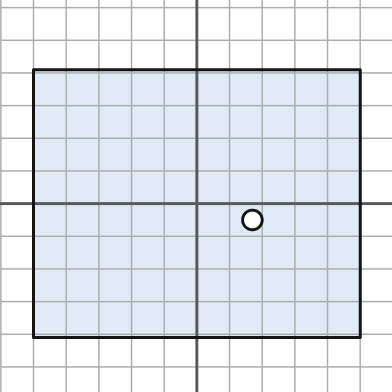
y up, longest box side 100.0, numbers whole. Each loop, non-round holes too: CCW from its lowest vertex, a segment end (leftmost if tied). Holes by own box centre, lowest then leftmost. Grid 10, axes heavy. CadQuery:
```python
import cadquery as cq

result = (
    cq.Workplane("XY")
    .moveTo(-50.0, -41.0)
    .lineTo(50.0, -41.0)
    .lineTo(50.0, 41.0)
    .lineTo(-50.0, 41.0)
    .close()
    .moveTo(17.0, -5.0)
    .circle(3.0)
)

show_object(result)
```